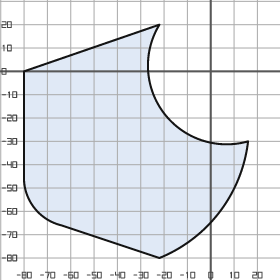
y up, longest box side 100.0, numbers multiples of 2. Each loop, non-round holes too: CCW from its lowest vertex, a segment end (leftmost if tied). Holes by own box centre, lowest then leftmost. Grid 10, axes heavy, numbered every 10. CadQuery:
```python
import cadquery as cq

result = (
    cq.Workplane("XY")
    .moveTo(-22.0, -80.0)
    .threePointArc((4.0, -60.0), (16.0, -30.0))
    .threePointArc((-20.0, -18.0), (-22.0, 20.0))
    .lineTo(-80.0, 0.0)
    .lineTo(-80.0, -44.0)
    .threePointArc((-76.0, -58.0), (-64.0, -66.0))
    .close()
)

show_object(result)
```